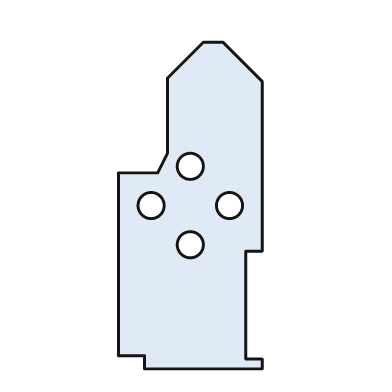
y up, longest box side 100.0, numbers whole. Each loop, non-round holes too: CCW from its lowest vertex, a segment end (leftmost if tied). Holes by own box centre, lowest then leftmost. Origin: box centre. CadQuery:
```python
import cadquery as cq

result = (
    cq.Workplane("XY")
    .moveTo(-14.0, -50.0)
    .lineTo(22.0, -50.0)
    .lineTo(22.0, -47.0)
    .lineTo(17.0, -47.0)
    .lineTo(17.0, -14.0)
    .lineTo(22.0, -14.0)
    .lineTo(22.0, 38.0)
    .lineTo(10.0, 50.0)
    .lineTo(4.0, 50.0)
    .lineTo(-7.0, 39.0)
    .lineTo(-7.0, 16.0)
    .lineTo(-10.0, 10.0)
    .lineTo(-22.0, 10.0)
    .lineTo(-22.0, -46.0)
    .lineTo(-14.0, -46.0)
    .close()
    .moveTo(0.0, -12.0)
    .circle(4.0)
    .moveTo(-12.0, 0.0)
    .circle(4.0)
    .moveTo(12.0, 0.0)
    .circle(4.0)
    .moveTo(0.0, 12.0)
    .circle(4.0)
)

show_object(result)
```